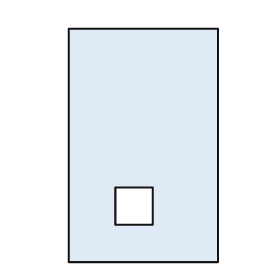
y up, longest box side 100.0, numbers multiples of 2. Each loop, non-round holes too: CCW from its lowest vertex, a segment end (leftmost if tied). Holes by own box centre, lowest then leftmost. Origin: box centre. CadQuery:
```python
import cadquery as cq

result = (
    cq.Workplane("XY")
    .moveTo(-32.0, -50.0)
    .lineTo(32.0, -50.0)
    .lineTo(32.0, 50.0)
    .lineTo(-32.0, 50.0)
    .close()
    .moveTo(-12.0, -34.0)
    .lineTo(4.0, -34.0)
    .lineTo(4.0, -18.0)
    .lineTo(-12.0, -18.0)
    .close()
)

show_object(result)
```